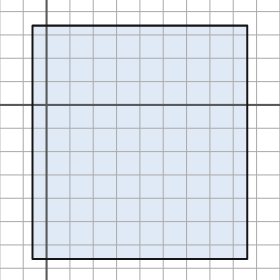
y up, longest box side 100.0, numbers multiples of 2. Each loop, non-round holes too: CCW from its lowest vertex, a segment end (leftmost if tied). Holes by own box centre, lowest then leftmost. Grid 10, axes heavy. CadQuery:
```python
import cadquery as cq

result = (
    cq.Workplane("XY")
    .moveTo(-6.0, -66.0)
    .lineTo(86.0, -66.0)
    .lineTo(86.0, 34.0)
    .lineTo(-6.0, 34.0)
    .close()
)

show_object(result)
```